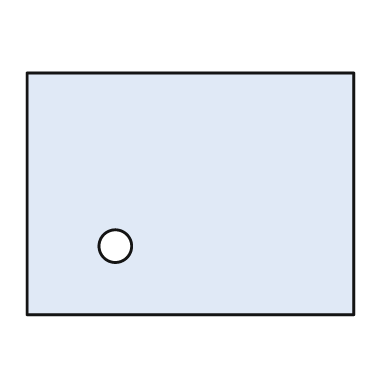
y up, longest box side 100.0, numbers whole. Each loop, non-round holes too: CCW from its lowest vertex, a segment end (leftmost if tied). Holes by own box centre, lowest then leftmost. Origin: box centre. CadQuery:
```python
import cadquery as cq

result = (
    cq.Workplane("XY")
    .moveTo(-50.0, -37.0)
    .lineTo(50.0, -37.0)
    .lineTo(50.0, 37.0)
    .lineTo(-50.0, 37.0)
    .close()
    .moveTo(-23.0, -16.0)
    .circle(5.0)
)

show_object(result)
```